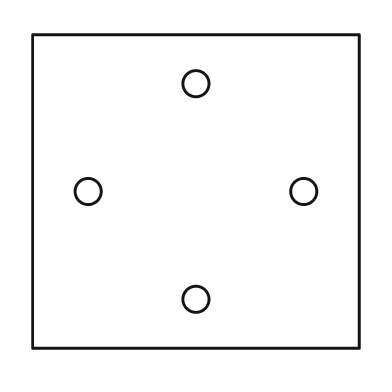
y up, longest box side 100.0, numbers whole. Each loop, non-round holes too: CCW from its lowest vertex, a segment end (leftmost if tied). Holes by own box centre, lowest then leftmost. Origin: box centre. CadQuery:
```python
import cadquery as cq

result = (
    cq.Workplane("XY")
    .moveTo(-50.0, -48.0)
    .lineTo(50.0, -48.0)
    .lineTo(50.0, 48.0)
    .lineTo(-50.0, 48.0)
    .close()
    .moveTo(0.0, -33.0)
    .circle(4.0)
    .moveTo(-33.0, 0.0)
    .circle(4.0)
    .moveTo(33.0, 0.0)
    .circle(4.0)
    .moveTo(0.0, 33.0)
    .circle(4.0)
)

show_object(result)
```